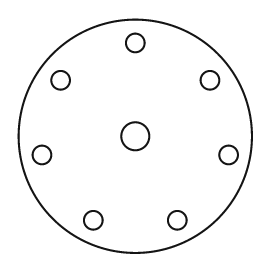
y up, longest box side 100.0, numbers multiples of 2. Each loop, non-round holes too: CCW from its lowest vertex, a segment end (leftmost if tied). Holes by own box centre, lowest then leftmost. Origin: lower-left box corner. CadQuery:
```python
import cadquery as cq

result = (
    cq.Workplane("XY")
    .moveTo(50.0, 50.0)
    .circle(50.0)
    .moveTo(32.0, 14.0)
    .circle(4.0)
    .moveTo(68.0, 14.0)
    .circle(4.0)
    .moveTo(10.0, 42.0)
    .circle(4.0)
    .moveTo(90.0, 42.0)
    .circle(4.0)
    .moveTo(50.0, 50.0)
    .circle(6.0)
    .moveTo(18.0, 74.0)
    .circle(4.0)
    .moveTo(82.0, 74.0)
    .circle(4.0)
    .moveTo(50.0, 90.0)
    .circle(4.0)
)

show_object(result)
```